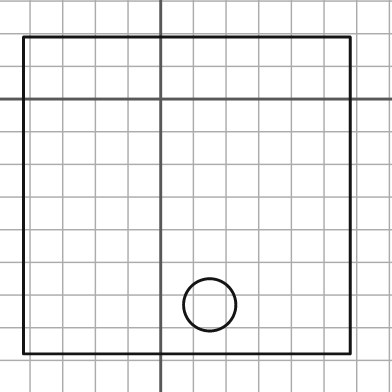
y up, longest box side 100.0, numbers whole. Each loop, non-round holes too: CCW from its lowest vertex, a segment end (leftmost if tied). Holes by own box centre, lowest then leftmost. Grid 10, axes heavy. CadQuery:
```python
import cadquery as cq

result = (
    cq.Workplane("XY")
    .moveTo(-42.0, -78.0)
    .lineTo(58.0, -78.0)
    .lineTo(58.0, 19.0)
    .lineTo(-42.0, 19.0)
    .close()
    .moveTo(15.0, -63.0)
    .circle(8.0)
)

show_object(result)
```